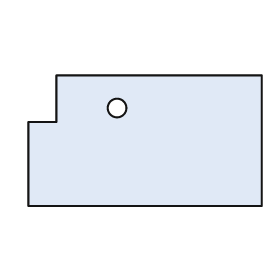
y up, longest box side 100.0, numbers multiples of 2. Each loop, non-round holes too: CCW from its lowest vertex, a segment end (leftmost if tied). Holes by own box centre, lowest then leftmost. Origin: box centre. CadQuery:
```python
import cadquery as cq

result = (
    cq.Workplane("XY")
    .moveTo(-50.0, -28.0)
    .lineTo(50.0, -28.0)
    .lineTo(50.0, 28.0)
    .lineTo(-38.0, 28.0)
    .lineTo(-38.0, 8.0)
    .lineTo(-50.0, 8.0)
    .close()
    .moveTo(-12.0, 14.0)
    .circle(4.0)
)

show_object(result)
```